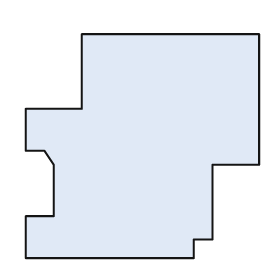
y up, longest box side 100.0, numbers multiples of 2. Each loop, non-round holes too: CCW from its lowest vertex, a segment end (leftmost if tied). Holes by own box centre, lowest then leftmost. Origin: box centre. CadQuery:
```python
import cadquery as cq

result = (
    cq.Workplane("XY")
    .moveTo(-50.0, -48.0)
    .lineTo(22.0, -48.0)
    .lineTo(22.0, -40.0)
    .lineTo(30.0, -40.0)
    .lineTo(30.0, -8.0)
    .lineTo(50.0, -8.0)
    .lineTo(50.0, 48.0)
    .lineTo(-26.0, 48.0)
    .lineTo(-26.0, 16.0)
    .lineTo(-50.0, 16.0)
    .lineTo(-50.0, -2.0)
    .lineTo(-42.0, -2.0)
    .lineTo(-38.0, -8.0)
    .lineTo(-38.0, -30.0)
    .lineTo(-50.0, -30.0)
    .close()
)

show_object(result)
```